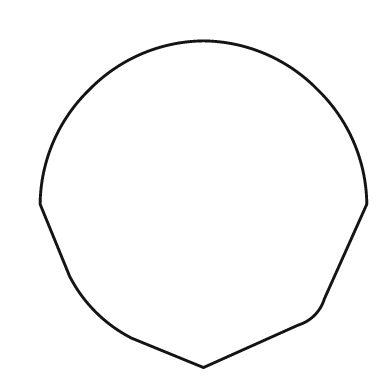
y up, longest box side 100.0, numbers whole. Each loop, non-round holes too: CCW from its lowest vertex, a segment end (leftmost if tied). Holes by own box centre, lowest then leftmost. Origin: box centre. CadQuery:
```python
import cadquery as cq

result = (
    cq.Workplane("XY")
    .moveTo(0.0, -50.0)
    .lineTo(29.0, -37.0)
    .threePointArc((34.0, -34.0), (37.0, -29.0))
    .lineTo(50.0, 0.0)
    .threePointArc((46.0, 19.0), (35.0, 35.0))
    .threePointArc((19.0, 46.0), (0.0, 50.0))
    .threePointArc((-19.0, 46.0), (-35.0, 35.0))
    .threePointArc((-46.0, 19.0), (-50.0, 0.0))
    .lineTo(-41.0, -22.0)
    .threePointArc((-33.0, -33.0), (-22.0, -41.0))
    .close()
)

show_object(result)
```